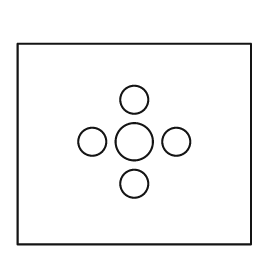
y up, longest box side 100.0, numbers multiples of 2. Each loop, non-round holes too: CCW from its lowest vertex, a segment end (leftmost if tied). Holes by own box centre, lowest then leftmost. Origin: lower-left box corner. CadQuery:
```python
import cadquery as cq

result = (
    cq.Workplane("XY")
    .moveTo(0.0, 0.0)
    .lineTo(100.0, 0.0)
    .lineTo(100.0, 86.0)
    .lineTo(0.0, 86.0)
    .close()
    .moveTo(50.0, 26.0)
    .circle(6.0)
    .moveTo(32.0, 44.0)
    .circle(6.0)
    .moveTo(50.0, 44.0)
    .circle(8.0)
    .moveTo(68.0, 44.0)
    .circle(6.0)
    .moveTo(50.0, 62.0)
    .circle(6.0)
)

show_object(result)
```